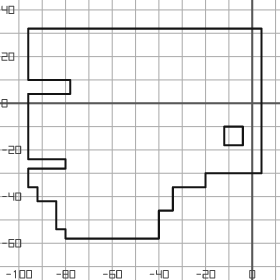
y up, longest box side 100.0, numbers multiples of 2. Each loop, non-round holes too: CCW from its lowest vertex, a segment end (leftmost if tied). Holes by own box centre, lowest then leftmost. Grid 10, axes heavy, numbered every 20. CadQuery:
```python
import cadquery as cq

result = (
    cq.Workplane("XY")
    .moveTo(-80.0, -58.0)
    .lineTo(-40.0, -58.0)
    .lineTo(-40.0, -46.0)
    .lineTo(-34.0, -46.0)
    .lineTo(-34.0, -36.0)
    .lineTo(-20.0, -36.0)
    .lineTo(-20.0, -30.0)
    .lineTo(4.0, -30.0)
    .lineTo(4.0, 32.0)
    .lineTo(-96.0, 32.0)
    .lineTo(-96.0, 10.0)
    .lineTo(-78.0, 10.0)
    .lineTo(-78.0, 4.0)
    .lineTo(-96.0, 4.0)
    .lineTo(-96.0, -24.0)
    .lineTo(-80.0, -24.0)
    .lineTo(-80.0, -28.0)
    .lineTo(-96.0, -28.0)
    .lineTo(-96.0, -36.0)
    .lineTo(-92.0, -36.0)
    .lineTo(-92.0, -42.0)
    .lineTo(-84.0, -42.0)
    .lineTo(-84.0, -54.0)
    .lineTo(-80.0, -54.0)
    .close()
    .moveTo(-12.0, -18.0)
    .lineTo(-4.0, -18.0)
    .lineTo(-4.0, -10.0)
    .lineTo(-12.0, -10.0)
    .close()
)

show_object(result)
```